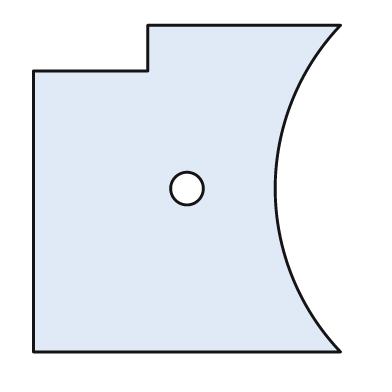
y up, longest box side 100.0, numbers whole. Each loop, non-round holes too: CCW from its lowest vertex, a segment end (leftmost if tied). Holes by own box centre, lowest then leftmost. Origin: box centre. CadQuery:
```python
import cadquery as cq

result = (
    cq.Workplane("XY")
    .moveTo(-47.0, -50.0)
    .lineTo(47.0, -50.0)
    .threePointArc((27.0, 0.0), (47.0, 50.0))
    .lineTo(-12.0, 50.0)
    .lineTo(-12.0, 36.0)
    .lineTo(-47.0, 36.0)
    .close()
    .moveTo(0.0, 0.0)
    .circle(5.0)
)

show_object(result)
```